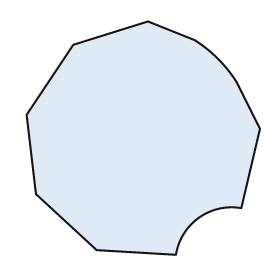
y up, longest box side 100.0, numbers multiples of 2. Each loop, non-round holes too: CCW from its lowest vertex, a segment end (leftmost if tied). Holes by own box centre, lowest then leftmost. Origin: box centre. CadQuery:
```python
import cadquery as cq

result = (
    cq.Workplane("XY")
    .moveTo(14.0, -50.0)
    .threePointArc((24.0, -34.0), (42.0, -30.0))
    .lineTo(50.0, 4.0)
    .lineTo(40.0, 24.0)
    .threePointArc((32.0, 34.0), (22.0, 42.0))
    .lineTo(2.0, 50.0)
    .lineTo(-30.0, 40.0)
    .lineTo(-50.0, 10.0)
    .lineTo(-46.0, -24.0)
    .lineTo(-20.0, -48.0)
    .close()
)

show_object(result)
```